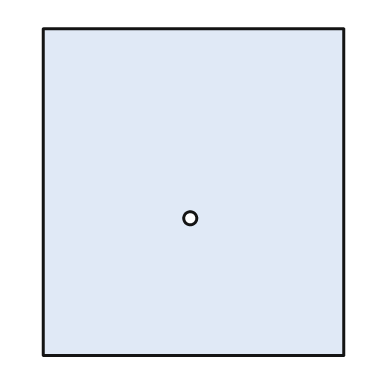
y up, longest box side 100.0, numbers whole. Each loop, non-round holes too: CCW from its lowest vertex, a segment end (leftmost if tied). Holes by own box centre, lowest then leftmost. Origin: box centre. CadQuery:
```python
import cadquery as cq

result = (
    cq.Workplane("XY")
    .moveTo(-46.0, -50.0)
    .lineTo(46.0, -50.0)
    .lineTo(46.0, 50.0)
    .lineTo(-46.0, 50.0)
    .close()
    .moveTo(-1.0, -8.0)
    .circle(2.0)
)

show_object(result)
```